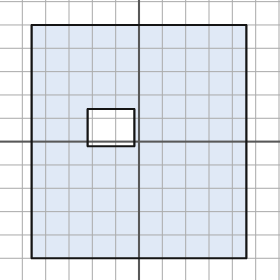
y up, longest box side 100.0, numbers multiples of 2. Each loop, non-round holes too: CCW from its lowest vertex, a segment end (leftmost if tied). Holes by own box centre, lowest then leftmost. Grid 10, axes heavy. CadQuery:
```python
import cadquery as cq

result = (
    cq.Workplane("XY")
    .moveTo(-46.0, -50.0)
    .lineTo(46.0, -50.0)
    .lineTo(46.0, 50.0)
    .lineTo(-46.0, 50.0)
    .close()
    .moveTo(-22.0, -2.0)
    .lineTo(-2.0, -2.0)
    .lineTo(-2.0, 14.0)
    .lineTo(-22.0, 14.0)
    .close()
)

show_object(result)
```